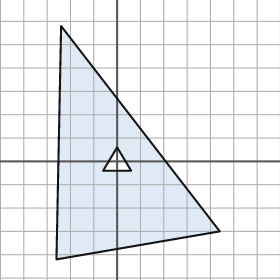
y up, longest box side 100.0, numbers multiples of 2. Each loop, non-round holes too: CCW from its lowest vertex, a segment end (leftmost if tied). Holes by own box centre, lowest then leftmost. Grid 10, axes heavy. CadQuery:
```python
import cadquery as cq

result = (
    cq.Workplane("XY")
    .moveTo(-26.0, -42.0)
    .lineTo(44.0, -30.0)
    .lineTo(-24.0, 58.0)
    .close()
    .moveTo(-6.0, -4.0)
    .lineTo(6.0, -4.0)
    .lineTo(0.0, 6.0)
    .close()
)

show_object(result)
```